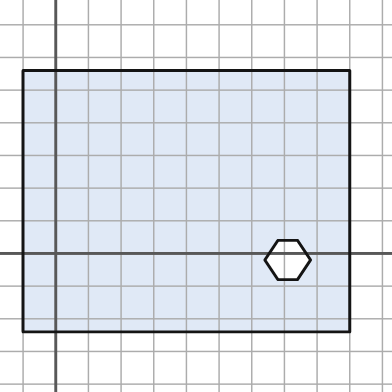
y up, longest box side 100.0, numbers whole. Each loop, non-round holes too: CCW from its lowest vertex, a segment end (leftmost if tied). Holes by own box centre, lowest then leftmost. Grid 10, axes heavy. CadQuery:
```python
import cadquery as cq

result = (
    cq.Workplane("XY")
    .moveTo(-10.0, -24.0)
    .lineTo(90.0, -24.0)
    .lineTo(90.0, 56.0)
    .lineTo(-10.0, 56.0)
    .close()
    .moveTo(68.0, -8.0)
    .lineTo(74.0, -8.0)
    .lineTo(78.0, -2.0)
    .lineTo(74.0, 4.0)
    .lineTo(68.0, 4.0)
    .lineTo(64.0, -2.0)
    .close()
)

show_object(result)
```